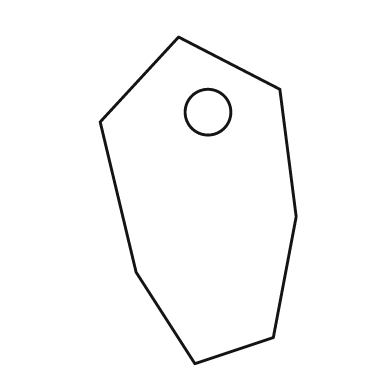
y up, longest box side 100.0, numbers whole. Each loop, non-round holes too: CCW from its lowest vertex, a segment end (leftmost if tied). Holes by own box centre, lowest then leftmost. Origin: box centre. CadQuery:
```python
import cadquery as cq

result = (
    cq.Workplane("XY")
    .moveTo(-1.0, -50.0)
    .lineTo(23.0, -42.0)
    .lineTo(30.0, -5.0)
    .lineTo(25.0, 34.0)
    .lineTo(-6.0, 50.0)
    .lineTo(-30.0, 24.0)
    .lineTo(-19.0, -22.0)
    .close()
    .moveTo(3.0, 27.0)
    .circle(7.0)
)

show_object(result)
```